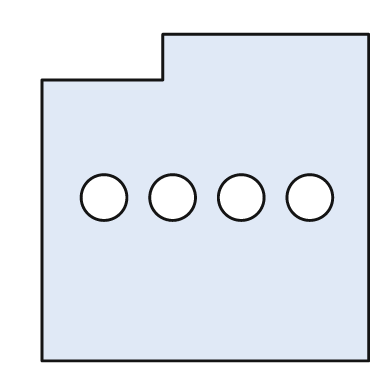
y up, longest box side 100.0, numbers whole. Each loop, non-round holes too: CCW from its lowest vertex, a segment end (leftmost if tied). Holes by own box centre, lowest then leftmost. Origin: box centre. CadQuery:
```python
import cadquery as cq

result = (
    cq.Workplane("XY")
    .moveTo(-50.0, -50.0)
    .lineTo(50.0, -50.0)
    .lineTo(50.0, 50.0)
    .lineTo(-13.0, 50.0)
    .lineTo(-13.0, 36.0)
    .lineTo(-50.0, 36.0)
    .close()
    .moveTo(-31.0, 0.0)
    .circle(7.0)
    .moveTo(-10.0, 0.0)
    .circle(7.0)
    .moveTo(11.0, 0.0)
    .circle(7.0)
    .moveTo(32.0, 0.0)
    .circle(7.0)
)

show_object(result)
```